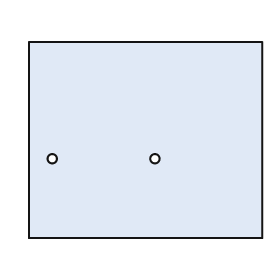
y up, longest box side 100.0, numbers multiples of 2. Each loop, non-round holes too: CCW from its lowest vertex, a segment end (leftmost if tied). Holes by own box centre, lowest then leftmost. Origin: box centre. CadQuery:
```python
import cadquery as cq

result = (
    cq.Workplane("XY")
    .moveTo(-50.0, -42.0)
    .lineTo(50.0, -42.0)
    .lineTo(50.0, 42.0)
    .lineTo(-50.0, 42.0)
    .close()
    .moveTo(-40.0, -8.0)
    .circle(2.0)
    .moveTo(4.0, -8.0)
    .circle(2.0)
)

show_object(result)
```